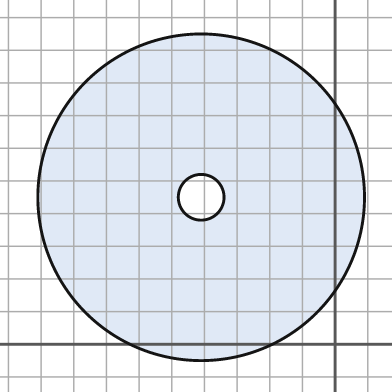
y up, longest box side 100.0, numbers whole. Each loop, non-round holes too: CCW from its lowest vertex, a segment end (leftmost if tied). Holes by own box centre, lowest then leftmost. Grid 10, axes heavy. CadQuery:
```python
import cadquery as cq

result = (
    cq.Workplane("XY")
    .moveTo(-41.0, 45.0)
    .circle(50.0)
    .moveTo(-41.0, 45.0)
    .circle(7.0)
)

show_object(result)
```